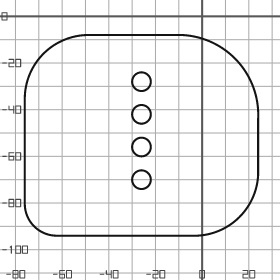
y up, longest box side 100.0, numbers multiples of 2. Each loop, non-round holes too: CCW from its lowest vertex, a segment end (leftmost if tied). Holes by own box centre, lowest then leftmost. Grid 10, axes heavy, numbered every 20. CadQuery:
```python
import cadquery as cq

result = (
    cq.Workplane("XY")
    .moveTo(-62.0, -94.0)
    .lineTo(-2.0, -94.0)
    .threePointArc((16.0, -86.0), (24.0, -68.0))
    .lineTo(24.0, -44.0)
    .threePointArc((14.0, -18.0), (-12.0, -8.0))
    .lineTo(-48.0, -8.0)
    .threePointArc((-68.0, -16.0), (-76.0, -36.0))
    .lineTo(-76.0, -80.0)
    .threePointArc((-72.0, -90.0), (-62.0, -94.0))
    .close()
    .moveTo(-26.0, -70.0)
    .circle(4.0)
    .moveTo(-26.0, -56.0)
    .circle(4.0)
    .moveTo(-26.0, -42.0)
    .circle(4.0)
    .moveTo(-26.0, -28.0)
    .circle(4.0)
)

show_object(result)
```